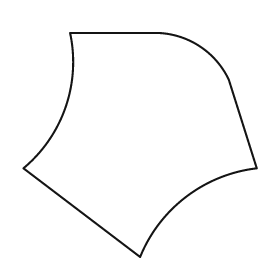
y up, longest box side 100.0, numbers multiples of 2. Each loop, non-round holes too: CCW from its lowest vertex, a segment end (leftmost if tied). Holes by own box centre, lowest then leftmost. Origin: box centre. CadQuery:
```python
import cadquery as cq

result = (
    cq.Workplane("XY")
    .moveTo(0.0, -48.0)
    .threePointArc((20.0, -22.0), (50.0, -10.0))
    .lineTo(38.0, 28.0)
    .threePointArc((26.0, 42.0), (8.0, 48.0))
    .lineTo(-30.0, 48.0)
    .threePointArc((-32.0, 16.0), (-50.0, -10.0))
    .close()
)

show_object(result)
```